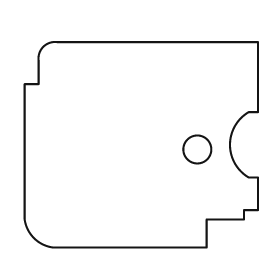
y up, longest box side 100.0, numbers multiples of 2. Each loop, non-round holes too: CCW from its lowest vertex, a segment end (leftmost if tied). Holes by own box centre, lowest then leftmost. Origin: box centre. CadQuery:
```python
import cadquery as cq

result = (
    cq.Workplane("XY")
    .moveTo(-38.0, -44.0)
    .lineTo(28.0, -44.0)
    .lineTo(28.0, -32.0)
    .lineTo(44.0, -32.0)
    .lineTo(44.0, -28.0)
    .lineTo(50.0, -28.0)
    .lineTo(50.0, -14.0)
    .lineTo(46.0, -14.0)
    .threePointArc((38.0, 0.0), (46.0, 14.0))
    .lineTo(50.0, 14.0)
    .lineTo(50.0, 44.0)
    .lineTo(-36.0, 44.0)
    .threePointArc((-42.0, 42.0), (-44.0, 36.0))
    .lineTo(-44.0, 26.0)
    .lineTo(-50.0, 26.0)
    .lineTo(-50.0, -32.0)
    .threePointArc((-46.0, -40.0), (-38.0, -44.0))
    .close()
    .moveTo(24.0, -2.0)
    .circle(6.0)
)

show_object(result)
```